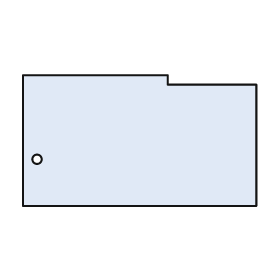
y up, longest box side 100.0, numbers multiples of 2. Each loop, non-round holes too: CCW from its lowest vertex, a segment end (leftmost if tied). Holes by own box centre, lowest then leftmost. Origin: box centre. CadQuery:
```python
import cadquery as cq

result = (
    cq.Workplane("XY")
    .moveTo(-50.0, -28.0)
    .lineTo(50.0, -28.0)
    .lineTo(50.0, 24.0)
    .lineTo(12.0, 24.0)
    .lineTo(12.0, 28.0)
    .lineTo(-50.0, 28.0)
    .close()
    .moveTo(-44.0, -8.0)
    .circle(2.0)
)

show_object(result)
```